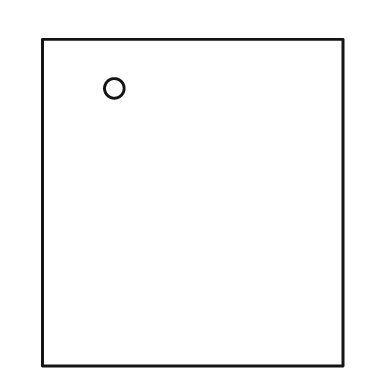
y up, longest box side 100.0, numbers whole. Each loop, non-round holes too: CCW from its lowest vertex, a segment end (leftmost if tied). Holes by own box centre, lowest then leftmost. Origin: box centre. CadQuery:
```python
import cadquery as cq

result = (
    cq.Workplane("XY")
    .moveTo(-46.0, -50.0)
    .lineTo(46.0, -50.0)
    .lineTo(46.0, 50.0)
    .lineTo(-46.0, 50.0)
    .close()
    .moveTo(-24.0, 35.0)
    .circle(3.0)
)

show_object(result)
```